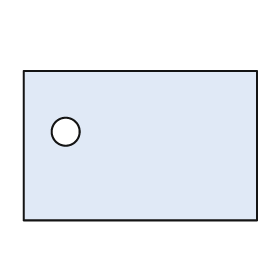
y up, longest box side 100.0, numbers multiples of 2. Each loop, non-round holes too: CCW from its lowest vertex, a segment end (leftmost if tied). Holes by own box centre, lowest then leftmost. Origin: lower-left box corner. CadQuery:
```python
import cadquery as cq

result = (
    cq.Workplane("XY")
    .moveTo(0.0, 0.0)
    .lineTo(100.0, 0.0)
    .lineTo(100.0, 64.0)
    .lineTo(0.0, 64.0)
    .close()
    .moveTo(18.0, 38.0)
    .circle(6.0)
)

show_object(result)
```